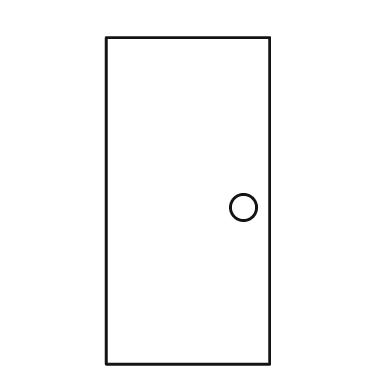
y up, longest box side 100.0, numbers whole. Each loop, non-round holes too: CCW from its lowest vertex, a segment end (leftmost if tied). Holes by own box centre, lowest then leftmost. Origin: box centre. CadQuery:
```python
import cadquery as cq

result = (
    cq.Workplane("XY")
    .moveTo(-25.0, -50.0)
    .lineTo(25.0, -50.0)
    .lineTo(25.0, 50.0)
    .lineTo(-25.0, 50.0)
    .close()
    .moveTo(17.0, -2.0)
    .circle(4.0)
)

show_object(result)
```